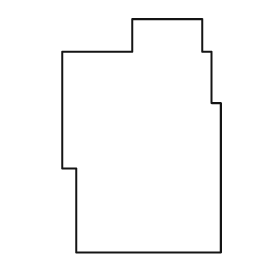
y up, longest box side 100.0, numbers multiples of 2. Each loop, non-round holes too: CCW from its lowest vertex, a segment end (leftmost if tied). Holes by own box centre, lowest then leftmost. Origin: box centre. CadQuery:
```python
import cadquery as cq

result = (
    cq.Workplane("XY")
    .moveTo(-28.0, -50.0)
    .lineTo(34.0, -50.0)
    .lineTo(34.0, 14.0)
    .lineTo(30.0, 14.0)
    .lineTo(30.0, 36.0)
    .lineTo(26.0, 36.0)
    .lineTo(26.0, 50.0)
    .lineTo(-4.0, 50.0)
    .lineTo(-4.0, 36.0)
    .lineTo(-34.0, 36.0)
    .lineTo(-34.0, -14.0)
    .lineTo(-28.0, -14.0)
    .close()
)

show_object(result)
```